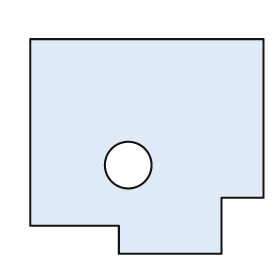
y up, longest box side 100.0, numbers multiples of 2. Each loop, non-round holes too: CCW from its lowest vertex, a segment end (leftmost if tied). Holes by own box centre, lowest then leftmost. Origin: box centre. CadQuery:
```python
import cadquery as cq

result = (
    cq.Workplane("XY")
    .moveTo(-12.0, -46.0)
    .lineTo(32.0, -46.0)
    .lineTo(32.0, -22.0)
    .lineTo(50.0, -22.0)
    .lineTo(50.0, 46.0)
    .lineTo(-50.0, 46.0)
    .lineTo(-50.0, -34.0)
    .lineTo(-12.0, -34.0)
    .close()
    .moveTo(-8.0, -8.0)
    .circle(10.0)
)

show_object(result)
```